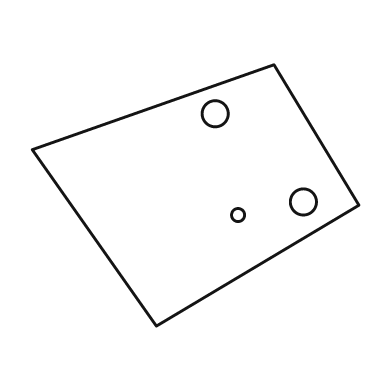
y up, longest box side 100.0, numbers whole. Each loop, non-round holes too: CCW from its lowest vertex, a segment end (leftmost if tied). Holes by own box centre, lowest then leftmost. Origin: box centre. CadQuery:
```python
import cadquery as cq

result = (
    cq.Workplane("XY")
    .moveTo(-12.0, -40.0)
    .lineTo(50.0, -3.0)
    .lineTo(24.0, 40.0)
    .lineTo(-50.0, 14.0)
    .close()
    .moveTo(13.0, -6.0)
    .circle(2.0)
    .moveTo(33.0, -2.0)
    .circle(4.0)
    .moveTo(6.0, 25.0)
    .circle(4.0)
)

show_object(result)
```